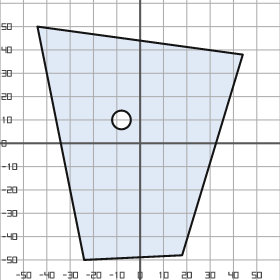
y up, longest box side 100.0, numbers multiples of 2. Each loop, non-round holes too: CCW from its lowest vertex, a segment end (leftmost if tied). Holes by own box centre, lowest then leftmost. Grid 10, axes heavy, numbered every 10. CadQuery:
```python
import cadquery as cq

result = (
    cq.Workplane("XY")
    .moveTo(-24.0, -50.0)
    .lineTo(18.0, -48.0)
    .lineTo(44.0, 38.0)
    .lineTo(-44.0, 50.0)
    .close()
    .moveTo(-8.0, 10.0)
    .circle(4.0)
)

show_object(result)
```